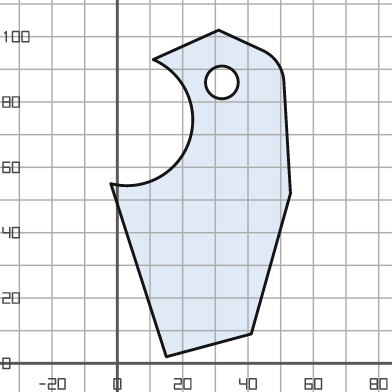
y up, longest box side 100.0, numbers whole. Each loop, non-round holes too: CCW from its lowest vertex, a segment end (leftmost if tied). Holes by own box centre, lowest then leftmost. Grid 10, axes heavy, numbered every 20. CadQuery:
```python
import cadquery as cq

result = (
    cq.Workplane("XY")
    .moveTo(15.0, 2.0)
    .lineTo(41.0, 9.0)
    .lineTo(53.0, 52.0)
    .lineTo(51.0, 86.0)
    .threePointArc((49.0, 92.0), (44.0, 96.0))
    .lineTo(31.0, 102.0)
    .lineTo(11.0, 93.0)
    .threePointArc((22.0, 68.0), (-2.0, 55.0))
    .close()
    .moveTo(32.0, 86.0)
    .circle(5.0)
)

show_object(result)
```